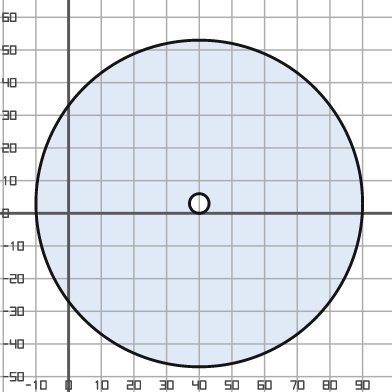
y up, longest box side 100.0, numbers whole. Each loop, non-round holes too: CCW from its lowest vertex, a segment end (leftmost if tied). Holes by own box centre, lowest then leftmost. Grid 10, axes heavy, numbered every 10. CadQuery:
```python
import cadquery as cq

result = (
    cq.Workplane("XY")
    .moveTo(40.0, 3.0)
    .circle(50.0)
    .moveTo(40.0, 3.0)
    .circle(3.0)
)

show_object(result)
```